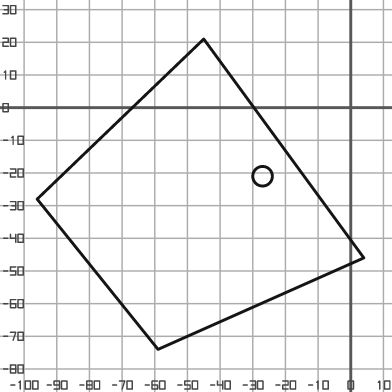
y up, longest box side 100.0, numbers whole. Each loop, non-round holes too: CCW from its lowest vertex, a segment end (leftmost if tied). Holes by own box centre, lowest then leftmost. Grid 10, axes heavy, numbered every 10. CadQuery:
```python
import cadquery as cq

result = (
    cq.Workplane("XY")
    .moveTo(-59.0, -74.0)
    .lineTo(4.0, -46.0)
    .lineTo(-45.0, 21.0)
    .lineTo(-96.0, -28.0)
    .close()
    .moveTo(-27.0, -21.0)
    .circle(3.0)
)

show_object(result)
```